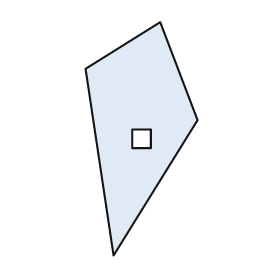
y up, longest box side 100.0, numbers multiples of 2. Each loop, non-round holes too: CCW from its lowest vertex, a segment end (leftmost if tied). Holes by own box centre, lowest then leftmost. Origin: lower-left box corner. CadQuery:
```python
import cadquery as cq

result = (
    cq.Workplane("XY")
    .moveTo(12.0, 0.0)
    .lineTo(48.0, 58.0)
    .lineTo(32.0, 100.0)
    .lineTo(0.0, 80.0)
    .close()
    .moveTo(20.0, 46.0)
    .lineTo(28.0, 46.0)
    .lineTo(28.0, 54.0)
    .lineTo(20.0, 54.0)
    .close()
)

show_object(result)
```